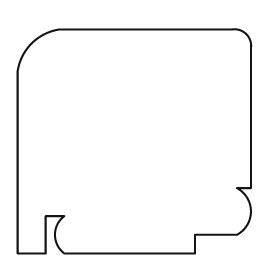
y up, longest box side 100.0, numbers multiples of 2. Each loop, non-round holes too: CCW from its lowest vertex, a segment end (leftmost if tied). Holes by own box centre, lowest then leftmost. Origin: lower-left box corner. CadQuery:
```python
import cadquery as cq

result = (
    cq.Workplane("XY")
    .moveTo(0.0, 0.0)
    .lineTo(12.0, 0.0)
    .lineTo(12.0, 16.0)
    .lineTo(20.0, 16.0)
    .threePointArc((16.0, 8.0), (20.0, 0.0))
    .lineTo(76.0, 0.0)
    .lineTo(76.0, 8.0)
    .lineTo(94.0, 8.0)
    .threePointArc((100.0, 18.0), (94.0, 28.0))
    .lineTo(100.0, 28.0)
    .lineTo(100.0, 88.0)
    .threePointArc((98.0, 94.0), (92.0, 96.0))
    .lineTo(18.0, 96.0)
    .threePointArc((6.0, 90.0), (0.0, 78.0))
    .close()
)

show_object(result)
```